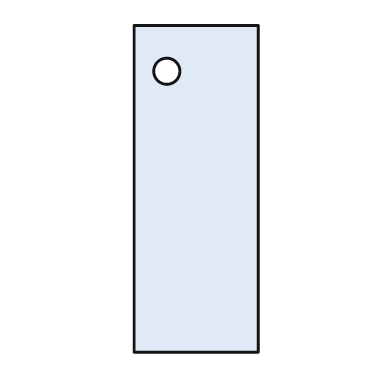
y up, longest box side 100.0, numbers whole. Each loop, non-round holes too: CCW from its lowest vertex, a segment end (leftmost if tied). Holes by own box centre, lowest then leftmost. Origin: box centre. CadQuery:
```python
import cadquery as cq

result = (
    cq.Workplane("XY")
    .moveTo(-19.0, -50.0)
    .lineTo(19.0, -50.0)
    .lineTo(19.0, 50.0)
    .lineTo(-19.0, 50.0)
    .close()
    .moveTo(-9.0, 36.0)
    .circle(4.0)
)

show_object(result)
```